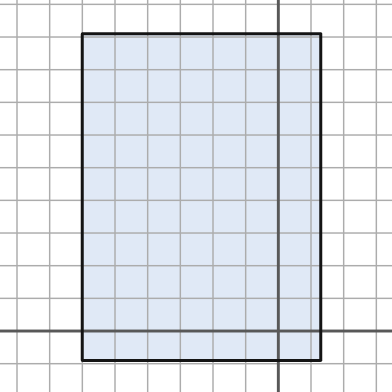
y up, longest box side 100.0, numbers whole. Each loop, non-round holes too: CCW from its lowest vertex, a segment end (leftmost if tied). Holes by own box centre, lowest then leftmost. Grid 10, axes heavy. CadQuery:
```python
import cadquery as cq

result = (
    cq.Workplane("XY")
    .moveTo(-60.0, -9.0)
    .lineTo(13.0, -9.0)
    .lineTo(13.0, 91.0)
    .lineTo(-60.0, 91.0)
    .close()
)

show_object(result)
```